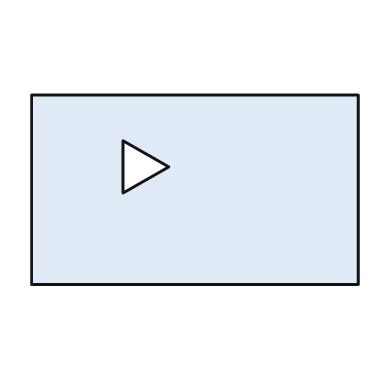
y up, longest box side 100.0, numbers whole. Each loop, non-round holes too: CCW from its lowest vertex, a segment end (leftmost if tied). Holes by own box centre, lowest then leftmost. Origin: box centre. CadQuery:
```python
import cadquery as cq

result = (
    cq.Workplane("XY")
    .moveTo(-50.0, -29.0)
    .lineTo(50.0, -29.0)
    .lineTo(50.0, 29.0)
    .lineTo(-50.0, 29.0)
    .close()
    .moveTo(-22.0, -1.0)
    .lineTo(-8.0, 7.0)
    .lineTo(-22.0, 15.0)
    .close()
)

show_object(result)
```